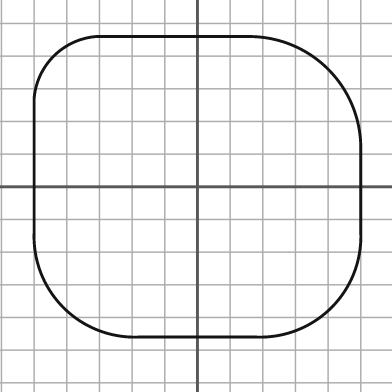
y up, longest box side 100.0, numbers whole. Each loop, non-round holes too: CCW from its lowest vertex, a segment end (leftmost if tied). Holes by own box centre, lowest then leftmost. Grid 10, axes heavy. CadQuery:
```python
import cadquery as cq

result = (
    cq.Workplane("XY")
    .moveTo(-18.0, -46.0)
    .lineTo(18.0, -46.0)
    .threePointArc((41.0, -37.0), (50.0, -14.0))
    .lineTo(50.0, 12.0)
    .threePointArc((40.0, 36.0), (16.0, 46.0))
    .lineTo(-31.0, 46.0)
    .threePointArc((-44.0, 40.0), (-50.0, 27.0))
    .lineTo(-50.0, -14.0)
    .threePointArc((-41.0, -37.0), (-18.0, -46.0))
    .close()
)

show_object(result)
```